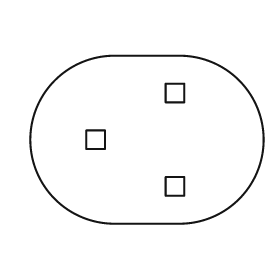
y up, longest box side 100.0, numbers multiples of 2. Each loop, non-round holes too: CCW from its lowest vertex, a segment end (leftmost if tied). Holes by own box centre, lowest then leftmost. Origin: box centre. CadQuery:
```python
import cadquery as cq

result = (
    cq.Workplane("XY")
    .moveTo(-14.0, -36.0)
    .lineTo(14.0, -36.0)
    .threePointArc((50.0, 0.0), (14.0, 36.0))
    .lineTo(-14.0, 36.0)
    .threePointArc((-50.0, 0.0), (-14.0, -36.0))
    .close()
    .moveTo(8.0, -24.0)
    .lineTo(16.0, -24.0)
    .lineTo(16.0, -16.0)
    .lineTo(8.0, -16.0)
    .close()
    .moveTo(-26.0, -4.0)
    .lineTo(-18.0, -4.0)
    .lineTo(-18.0, 4.0)
    .lineTo(-26.0, 4.0)
    .close()
    .moveTo(8.0, 16.0)
    .lineTo(16.0, 16.0)
    .lineTo(16.0, 24.0)
    .lineTo(8.0, 24.0)
    .close()
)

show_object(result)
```